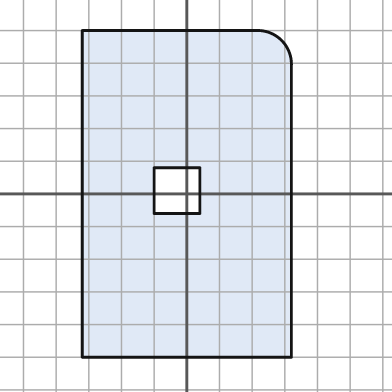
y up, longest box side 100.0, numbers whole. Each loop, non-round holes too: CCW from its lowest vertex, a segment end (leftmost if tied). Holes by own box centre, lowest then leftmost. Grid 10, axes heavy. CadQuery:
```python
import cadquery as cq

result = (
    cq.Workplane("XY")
    .moveTo(-32.0, -50.0)
    .lineTo(32.0, -50.0)
    .lineTo(32.0, 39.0)
    .threePointArc((29.0, 47.0), (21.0, 50.0))
    .lineTo(-32.0, 50.0)
    .close()
    .moveTo(-10.0, -6.0)
    .lineTo(4.0, -6.0)
    .lineTo(4.0, 8.0)
    .lineTo(-10.0, 8.0)
    .close()
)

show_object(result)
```